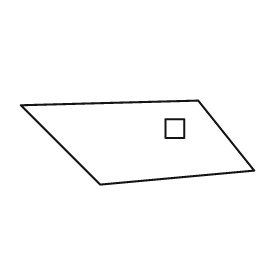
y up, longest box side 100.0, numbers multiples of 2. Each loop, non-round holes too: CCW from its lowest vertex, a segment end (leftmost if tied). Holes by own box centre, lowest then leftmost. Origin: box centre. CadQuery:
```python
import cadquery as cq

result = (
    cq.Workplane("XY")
    .moveTo(-16.0, -18.0)
    .lineTo(50.0, -12.0)
    .lineTo(26.0, 18.0)
    .lineTo(-50.0, 16.0)
    .close()
    .moveTo(12.0, 2.0)
    .lineTo(20.0, 2.0)
    .lineTo(20.0, 10.0)
    .lineTo(12.0, 10.0)
    .close()
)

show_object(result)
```